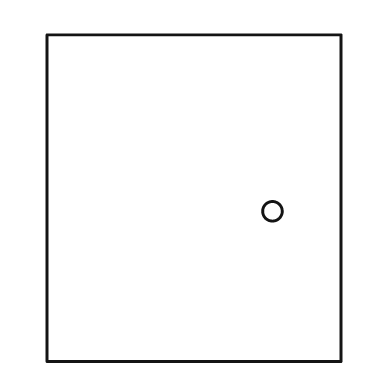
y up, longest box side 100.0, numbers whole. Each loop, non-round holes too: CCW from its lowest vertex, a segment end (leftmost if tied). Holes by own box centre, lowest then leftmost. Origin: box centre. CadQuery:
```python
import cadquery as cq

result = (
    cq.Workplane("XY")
    .moveTo(-45.0, -50.0)
    .lineTo(45.0, -50.0)
    .lineTo(45.0, 50.0)
    .lineTo(-45.0, 50.0)
    .close()
    .moveTo(24.0, -4.0)
    .circle(3.0)
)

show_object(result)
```